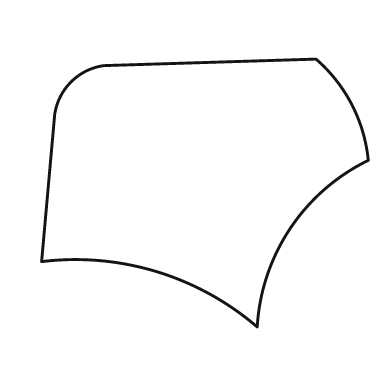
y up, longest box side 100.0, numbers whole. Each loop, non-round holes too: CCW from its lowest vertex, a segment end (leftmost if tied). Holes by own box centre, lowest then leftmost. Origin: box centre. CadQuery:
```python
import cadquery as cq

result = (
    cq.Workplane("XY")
    .moveTo(16.0, -41.0)
    .threePointArc((26.0, -11.0), (50.0, 10.0))
    .threePointArc((45.0, 27.0), (34.0, 41.0))
    .lineTo(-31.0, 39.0)
    .threePointArc((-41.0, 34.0), (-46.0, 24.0))
    .lineTo(-50.0, -21.0)
    .threePointArc((-15.0, -24.0), (16.0, -41.0))
    .close()
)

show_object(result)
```